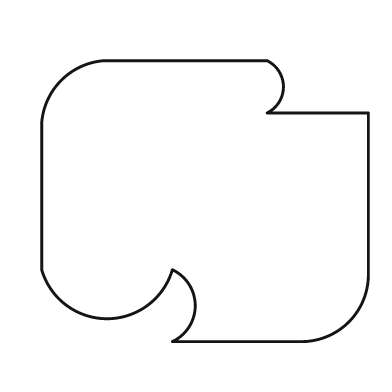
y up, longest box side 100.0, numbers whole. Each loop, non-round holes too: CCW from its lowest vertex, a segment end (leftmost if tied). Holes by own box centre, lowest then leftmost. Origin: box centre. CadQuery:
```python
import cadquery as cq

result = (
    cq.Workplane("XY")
    .moveTo(-10.0, -43.0)
    .lineTo(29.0, -43.0)
    .threePointArc((44.0, -37.0), (50.0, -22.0))
    .lineTo(50.0, 27.0)
    .lineTo(19.0, 27.0)
    .threePointArc((24.0, 35.0), (19.0, 43.0))
    .lineTo(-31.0, 43.0)
    .threePointArc((-44.0, 37.0), (-50.0, 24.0))
    .lineTo(-50.0, -21.0)
    .threePointArc((-30.0, -36.0), (-10.0, -21.0))
    .threePointArc((-3.0, -32.0), (-10.0, -43.0))
    .close()
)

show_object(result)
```